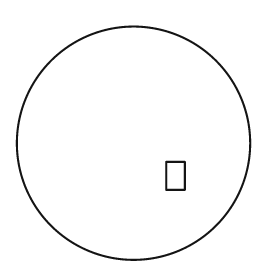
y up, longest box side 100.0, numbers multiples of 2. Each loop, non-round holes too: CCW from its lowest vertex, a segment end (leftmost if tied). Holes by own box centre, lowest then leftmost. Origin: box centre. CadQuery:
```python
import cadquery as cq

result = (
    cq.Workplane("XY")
    .moveTo(0.0, 0.0)
    .circle(50.0)
    .moveTo(14.0, -20.0)
    .lineTo(22.0, -20.0)
    .lineTo(22.0, -8.0)
    .lineTo(14.0, -8.0)
    .close()
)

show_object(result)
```